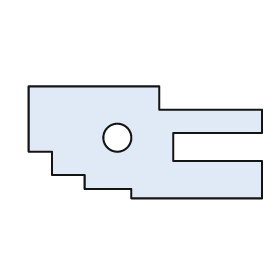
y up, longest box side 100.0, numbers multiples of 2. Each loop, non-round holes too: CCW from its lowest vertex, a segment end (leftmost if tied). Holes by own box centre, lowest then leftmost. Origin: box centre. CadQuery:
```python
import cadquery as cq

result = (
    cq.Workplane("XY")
    .moveTo(-6.0, -24.0)
    .lineTo(50.0, -24.0)
    .lineTo(50.0, -8.0)
    .lineTo(12.0, -8.0)
    .lineTo(12.0, 4.0)
    .lineTo(50.0, 4.0)
    .lineTo(50.0, 14.0)
    .lineTo(6.0, 14.0)
    .lineTo(6.0, 24.0)
    .lineTo(-50.0, 24.0)
    .lineTo(-50.0, -4.0)
    .lineTo(-40.0, -4.0)
    .lineTo(-40.0, -14.0)
    .lineTo(-26.0, -14.0)
    .lineTo(-26.0, -20.0)
    .lineTo(-6.0, -20.0)
    .close()
    .moveTo(-12.0, 2.0)
    .circle(6.0)
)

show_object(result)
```